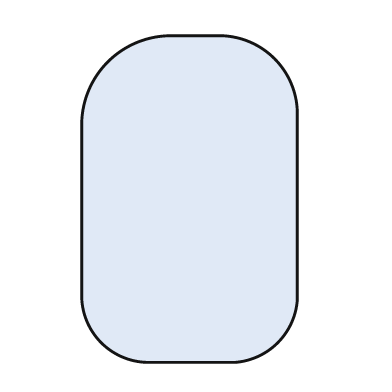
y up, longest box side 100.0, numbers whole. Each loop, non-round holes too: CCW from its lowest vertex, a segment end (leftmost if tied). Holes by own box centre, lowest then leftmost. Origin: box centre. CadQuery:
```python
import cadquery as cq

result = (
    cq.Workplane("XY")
    .moveTo(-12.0, -50.0)
    .lineTo(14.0, -50.0)
    .threePointArc((27.0, -44.0), (33.0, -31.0))
    .lineTo(33.0, 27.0)
    .threePointArc((26.0, 43.0), (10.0, 50.0))
    .lineTo(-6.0, 50.0)
    .threePointArc((-25.0, 42.0), (-33.0, 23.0))
    .lineTo(-33.0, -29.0)
    .threePointArc((-27.0, -44.0), (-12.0, -50.0))
    .close()
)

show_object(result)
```